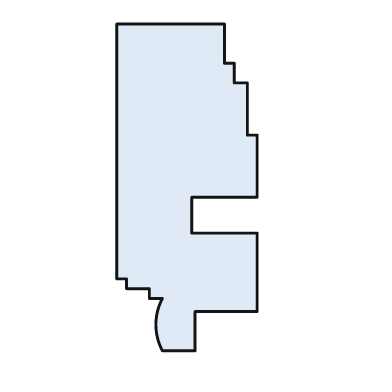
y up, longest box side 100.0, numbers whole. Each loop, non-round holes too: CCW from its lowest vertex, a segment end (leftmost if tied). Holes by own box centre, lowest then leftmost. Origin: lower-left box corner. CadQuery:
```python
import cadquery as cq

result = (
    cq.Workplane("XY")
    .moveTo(14.0, 0.0)
    .lineTo(24.0, 0.0)
    .lineTo(24.0, 12.0)
    .lineTo(43.0, 12.0)
    .lineTo(43.0, 36.0)
    .lineTo(23.0, 36.0)
    .lineTo(23.0, 47.0)
    .lineTo(43.0, 47.0)
    .lineTo(43.0, 66.0)
    .lineTo(40.0, 66.0)
    .lineTo(40.0, 82.0)
    .lineTo(36.0, 82.0)
    .lineTo(36.0, 88.0)
    .lineTo(33.0, 88.0)
    .lineTo(33.0, 100.0)
    .lineTo(0.0, 100.0)
    .lineTo(0.0, 22.0)
    .lineTo(3.0, 22.0)
    .lineTo(3.0, 19.0)
    .lineTo(10.0, 19.0)
    .lineTo(10.0, 16.0)
    .lineTo(14.0, 16.0)
    .threePointArc((12.0, 8.0), (14.0, 0.0))
    .close()
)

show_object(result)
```